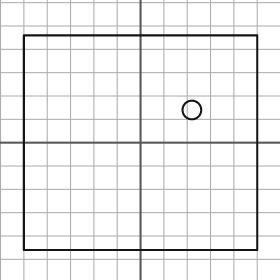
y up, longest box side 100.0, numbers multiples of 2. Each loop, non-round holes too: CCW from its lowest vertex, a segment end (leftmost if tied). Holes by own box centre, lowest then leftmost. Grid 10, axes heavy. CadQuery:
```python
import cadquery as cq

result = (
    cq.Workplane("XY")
    .moveTo(-50.0, -46.0)
    .lineTo(50.0, -46.0)
    .lineTo(50.0, 46.0)
    .lineTo(-50.0, 46.0)
    .close()
    .moveTo(22.0, 14.0)
    .circle(4.0)
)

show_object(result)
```